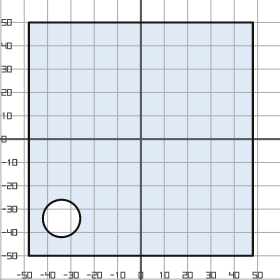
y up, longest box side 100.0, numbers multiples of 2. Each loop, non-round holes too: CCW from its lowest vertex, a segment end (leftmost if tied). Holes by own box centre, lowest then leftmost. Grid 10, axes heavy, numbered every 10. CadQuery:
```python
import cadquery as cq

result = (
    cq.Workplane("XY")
    .moveTo(-48.0, -50.0)
    .lineTo(48.0, -50.0)
    .lineTo(48.0, 50.0)
    .lineTo(-48.0, 50.0)
    .close()
    .moveTo(-34.0, -34.0)
    .circle(8.0)
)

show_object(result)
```